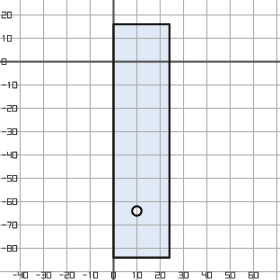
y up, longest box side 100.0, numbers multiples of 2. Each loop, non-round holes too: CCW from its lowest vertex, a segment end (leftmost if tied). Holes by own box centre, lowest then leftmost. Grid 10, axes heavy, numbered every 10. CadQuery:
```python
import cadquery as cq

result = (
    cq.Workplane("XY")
    .moveTo(0.0, -84.0)
    .lineTo(24.0, -84.0)
    .lineTo(24.0, 16.0)
    .lineTo(0.0, 16.0)
    .close()
    .moveTo(10.0, -64.0)
    .circle(2.0)
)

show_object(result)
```